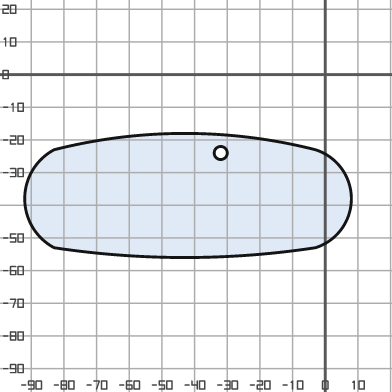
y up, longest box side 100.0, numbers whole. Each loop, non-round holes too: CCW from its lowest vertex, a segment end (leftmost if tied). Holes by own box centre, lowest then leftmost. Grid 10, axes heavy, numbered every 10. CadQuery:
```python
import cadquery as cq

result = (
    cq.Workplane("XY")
    .moveTo(-83.0, -53.0)
    .threePointArc((-43.0, -56.0), (-3.0, -53.0))
    .threePointArc((8.0, -38.0), (-3.0, -23.0))
    .threePointArc((-43.0, -18.0), (-83.0, -23.0))
    .threePointArc((-92.0, -38.0), (-83.0, -53.0))
    .close()
    .moveTo(-32.0, -24.0)
    .circle(2.0)
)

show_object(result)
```